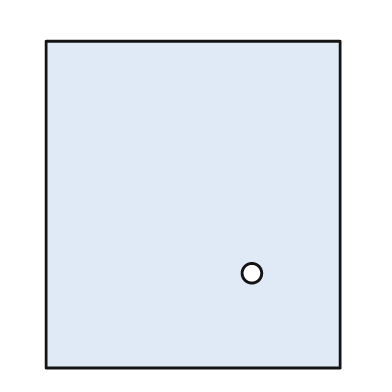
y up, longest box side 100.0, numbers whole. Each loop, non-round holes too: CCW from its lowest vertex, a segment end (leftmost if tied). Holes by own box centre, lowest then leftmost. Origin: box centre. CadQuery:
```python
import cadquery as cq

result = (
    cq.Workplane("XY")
    .moveTo(-45.0, -50.0)
    .lineTo(45.0, -50.0)
    .lineTo(45.0, 50.0)
    .lineTo(-45.0, 50.0)
    .close()
    .moveTo(18.0, -21.0)
    .circle(3.0)
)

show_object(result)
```